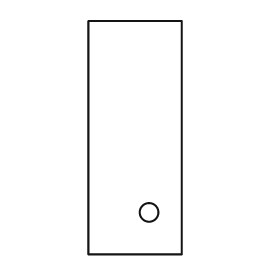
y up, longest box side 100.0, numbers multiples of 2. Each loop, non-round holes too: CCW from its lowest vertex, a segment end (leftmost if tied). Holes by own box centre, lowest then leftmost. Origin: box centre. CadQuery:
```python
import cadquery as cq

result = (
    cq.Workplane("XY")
    .moveTo(-20.0, -50.0)
    .lineTo(20.0, -50.0)
    .lineTo(20.0, 50.0)
    .lineTo(-20.0, 50.0)
    .close()
    .moveTo(6.0, -32.0)
    .circle(4.0)
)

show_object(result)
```